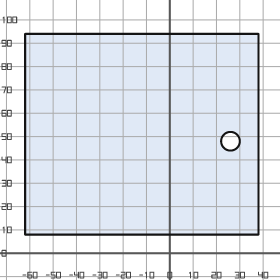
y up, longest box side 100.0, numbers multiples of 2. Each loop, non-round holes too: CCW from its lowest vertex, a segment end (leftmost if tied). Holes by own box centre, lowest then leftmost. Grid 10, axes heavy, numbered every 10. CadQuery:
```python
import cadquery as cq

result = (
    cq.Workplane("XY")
    .moveTo(-62.0, 8.0)
    .lineTo(38.0, 8.0)
    .lineTo(38.0, 94.0)
    .lineTo(-62.0, 94.0)
    .close()
    .moveTo(26.0, 48.0)
    .circle(4.0)
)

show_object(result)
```